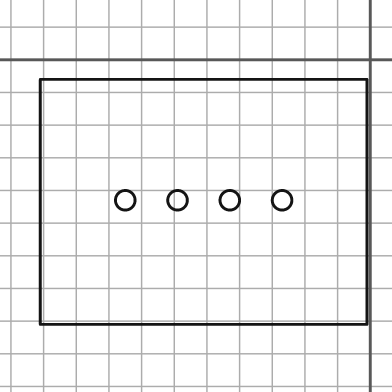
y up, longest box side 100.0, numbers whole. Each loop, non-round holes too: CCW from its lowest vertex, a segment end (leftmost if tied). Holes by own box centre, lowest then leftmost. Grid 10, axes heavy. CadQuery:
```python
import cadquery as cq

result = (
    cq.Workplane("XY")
    .moveTo(-101.0, -81.0)
    .lineTo(-1.0, -81.0)
    .lineTo(-1.0, -6.0)
    .lineTo(-101.0, -6.0)
    .close()
    .moveTo(-75.0, -43.0)
    .circle(3.0)
    .moveTo(-59.0, -43.0)
    .circle(3.0)
    .moveTo(-43.0, -43.0)
    .circle(3.0)
    .moveTo(-27.0, -43.0)
    .circle(3.0)
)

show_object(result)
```